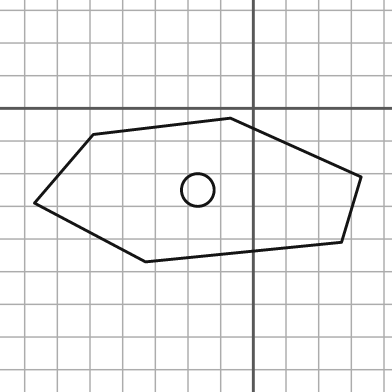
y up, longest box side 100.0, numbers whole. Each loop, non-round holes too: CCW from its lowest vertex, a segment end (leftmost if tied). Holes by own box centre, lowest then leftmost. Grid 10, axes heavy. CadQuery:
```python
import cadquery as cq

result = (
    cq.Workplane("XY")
    .moveTo(-33.0, -47.0)
    .lineTo(27.0, -41.0)
    .lineTo(33.0, -21.0)
    .lineTo(-7.0, -3.0)
    .lineTo(-49.0, -8.0)
    .lineTo(-67.0, -29.0)
    .close()
    .moveTo(-17.0, -25.0)
    .circle(5.0)
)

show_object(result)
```